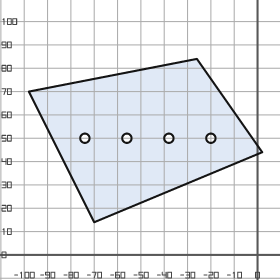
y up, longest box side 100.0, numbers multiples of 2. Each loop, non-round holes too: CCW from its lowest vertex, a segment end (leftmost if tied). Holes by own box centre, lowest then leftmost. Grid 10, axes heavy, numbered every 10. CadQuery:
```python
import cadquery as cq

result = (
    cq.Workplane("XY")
    .moveTo(-70.0, 14.0)
    .lineTo(2.0, 44.0)
    .lineTo(-26.0, 84.0)
    .lineTo(-98.0, 70.0)
    .close()
    .moveTo(-74.0, 50.0)
    .circle(2.0)
    .moveTo(-56.0, 50.0)
    .circle(2.0)
    .moveTo(-38.0, 50.0)
    .circle(2.0)
    .moveTo(-20.0, 50.0)
    .circle(2.0)
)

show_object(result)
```